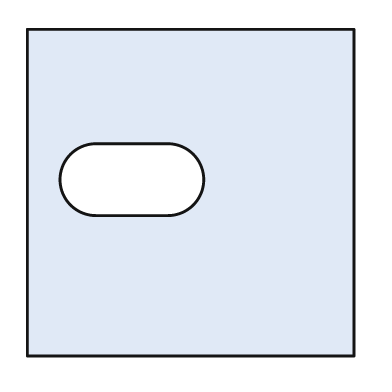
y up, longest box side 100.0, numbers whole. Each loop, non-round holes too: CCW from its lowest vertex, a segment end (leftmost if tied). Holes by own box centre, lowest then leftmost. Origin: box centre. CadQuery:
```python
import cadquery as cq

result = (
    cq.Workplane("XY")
    .moveTo(-50.0, -50.0)
    .lineTo(50.0, -50.0)
    .lineTo(50.0, 50.0)
    .lineTo(-50.0, 50.0)
    .close()
    .moveTo(-29.0, -7.0)
    .lineTo(-7.0, -7.0)
    .threePointArc((4.0, 4.0), (-7.0, 15.0))
    .lineTo(-29.0, 15.0)
    .threePointArc((-40.0, 4.0), (-29.0, -7.0))
    .close()
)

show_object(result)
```